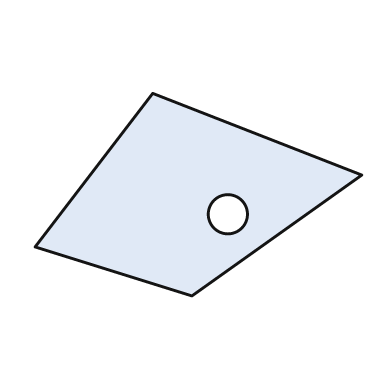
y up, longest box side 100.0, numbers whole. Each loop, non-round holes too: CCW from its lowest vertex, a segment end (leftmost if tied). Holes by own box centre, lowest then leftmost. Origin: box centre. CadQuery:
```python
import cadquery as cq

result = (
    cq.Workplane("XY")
    .moveTo(-2.0, -31.0)
    .lineTo(50.0, 6.0)
    .lineTo(-14.0, 31.0)
    .lineTo(-50.0, -16.0)
    .close()
    .moveTo(9.0, -6.0)
    .circle(6.0)
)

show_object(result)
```